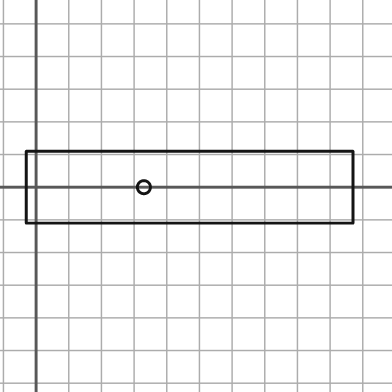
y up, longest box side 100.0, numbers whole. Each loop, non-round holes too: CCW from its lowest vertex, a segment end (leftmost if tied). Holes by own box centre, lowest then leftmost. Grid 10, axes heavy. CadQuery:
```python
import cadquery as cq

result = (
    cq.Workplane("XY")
    .moveTo(-3.0, -11.0)
    .lineTo(97.0, -11.0)
    .lineTo(97.0, 11.0)
    .lineTo(-3.0, 11.0)
    .close()
    .moveTo(33.0, 0.0)
    .circle(2.0)
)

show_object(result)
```